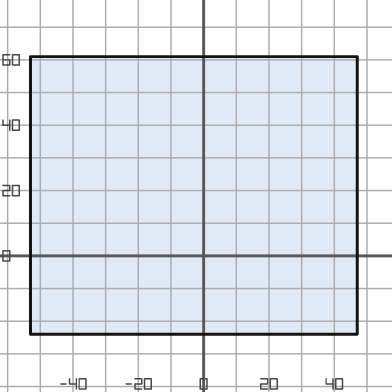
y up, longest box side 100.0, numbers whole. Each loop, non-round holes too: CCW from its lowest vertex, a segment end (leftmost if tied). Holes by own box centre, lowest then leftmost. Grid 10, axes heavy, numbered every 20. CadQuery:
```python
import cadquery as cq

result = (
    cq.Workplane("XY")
    .moveTo(-53.0, -24.0)
    .lineTo(47.0, -24.0)
    .lineTo(47.0, 61.0)
    .lineTo(-53.0, 61.0)
    .close()
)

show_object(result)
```